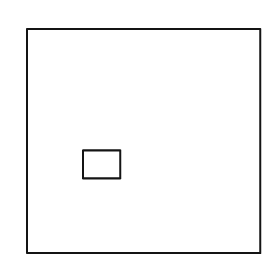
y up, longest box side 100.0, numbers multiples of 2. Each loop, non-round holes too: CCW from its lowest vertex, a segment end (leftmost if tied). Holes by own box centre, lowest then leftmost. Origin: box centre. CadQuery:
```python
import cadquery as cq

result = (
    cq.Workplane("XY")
    .moveTo(-50.0, -48.0)
    .lineTo(50.0, -48.0)
    .lineTo(50.0, 48.0)
    .lineTo(-50.0, 48.0)
    .close()
    .moveTo(-26.0, -16.0)
    .lineTo(-10.0, -16.0)
    .lineTo(-10.0, -4.0)
    .lineTo(-26.0, -4.0)
    .close()
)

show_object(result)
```